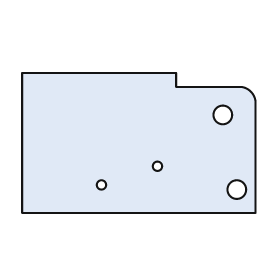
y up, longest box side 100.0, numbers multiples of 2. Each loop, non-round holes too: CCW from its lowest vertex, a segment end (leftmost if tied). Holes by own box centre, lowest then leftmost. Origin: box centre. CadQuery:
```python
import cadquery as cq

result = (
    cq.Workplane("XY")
    .moveTo(-50.0, -30.0)
    .lineTo(50.0, -30.0)
    .lineTo(50.0, 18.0)
    .threePointArc((48.0, 22.0), (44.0, 24.0))
    .lineTo(16.0, 24.0)
    .lineTo(16.0, 30.0)
    .lineTo(-50.0, 30.0)
    .close()
    .moveTo(42.0, -20.0)
    .circle(4.0)
    .moveTo(-16.0, -18.0)
    .circle(2.0)
    .moveTo(8.0, -10.0)
    .circle(2.0)
    .moveTo(36.0, 12.0)
    .circle(4.0)
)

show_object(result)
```